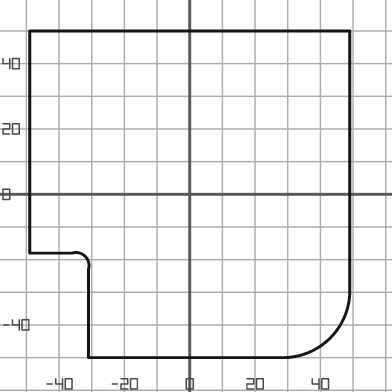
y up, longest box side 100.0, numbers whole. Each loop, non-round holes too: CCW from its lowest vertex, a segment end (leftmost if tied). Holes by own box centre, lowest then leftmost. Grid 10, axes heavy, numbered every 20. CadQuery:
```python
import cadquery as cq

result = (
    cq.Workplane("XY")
    .moveTo(-31.0, -50.0)
    .lineTo(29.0, -50.0)
    .threePointArc((43.0, -44.0), (49.0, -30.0))
    .lineTo(49.0, 50.0)
    .lineTo(-49.0, 50.0)
    .lineTo(-49.0, -18.0)
    .lineTo(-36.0, -18.0)
    .threePointArc((-32.0, -19.0), (-31.0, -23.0))
    .close()
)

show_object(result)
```